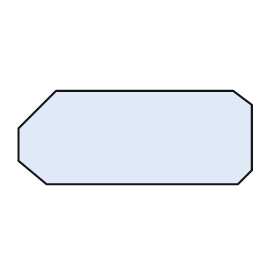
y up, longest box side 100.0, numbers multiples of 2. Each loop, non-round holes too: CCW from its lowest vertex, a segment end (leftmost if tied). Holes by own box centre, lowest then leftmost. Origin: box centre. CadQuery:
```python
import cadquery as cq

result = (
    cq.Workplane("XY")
    .moveTo(-38.0, -20.0)
    .lineTo(44.0, -20.0)
    .lineTo(50.0, -14.0)
    .lineTo(50.0, 14.0)
    .lineTo(42.0, 20.0)
    .lineTo(-34.0, 20.0)
    .lineTo(-50.0, 4.0)
    .lineTo(-50.0, -10.0)
    .close()
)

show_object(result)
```